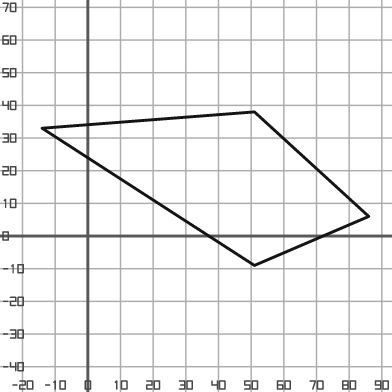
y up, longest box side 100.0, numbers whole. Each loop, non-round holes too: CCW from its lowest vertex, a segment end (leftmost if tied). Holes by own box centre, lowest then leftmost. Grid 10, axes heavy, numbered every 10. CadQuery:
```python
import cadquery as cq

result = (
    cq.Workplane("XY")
    .moveTo(51.0, -9.0)
    .lineTo(86.0, 6.0)
    .lineTo(51.0, 38.0)
    .lineTo(-14.0, 33.0)
    .close()
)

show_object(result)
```